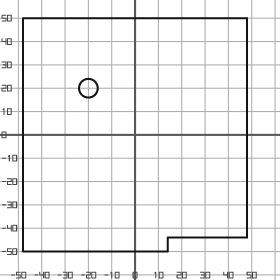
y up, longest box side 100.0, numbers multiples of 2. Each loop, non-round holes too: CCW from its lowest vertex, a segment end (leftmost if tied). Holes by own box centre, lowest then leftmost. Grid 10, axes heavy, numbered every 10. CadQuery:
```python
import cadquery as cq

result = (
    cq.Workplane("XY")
    .moveTo(-48.0, -50.0)
    .lineTo(14.0, -50.0)
    .lineTo(14.0, -44.0)
    .lineTo(48.0, -44.0)
    .lineTo(48.0, 50.0)
    .lineTo(-48.0, 50.0)
    .close()
    .moveTo(-20.0, 20.0)
    .circle(4.0)
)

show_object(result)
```